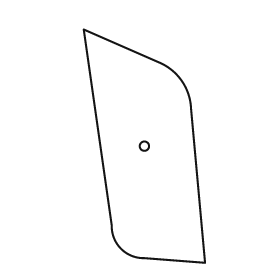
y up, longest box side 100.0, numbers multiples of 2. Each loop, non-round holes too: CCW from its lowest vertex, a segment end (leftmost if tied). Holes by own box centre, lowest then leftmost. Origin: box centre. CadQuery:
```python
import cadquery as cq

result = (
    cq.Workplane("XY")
    .moveTo(26.0, -50.0)
    .lineTo(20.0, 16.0)
    .threePointArc((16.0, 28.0), (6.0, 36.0))
    .lineTo(-26.0, 50.0)
    .lineTo(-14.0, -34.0)
    .threePointArc((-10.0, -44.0), (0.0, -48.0))
    .close()
    .moveTo(0.0, 0.0)
    .circle(2.0)
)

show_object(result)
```